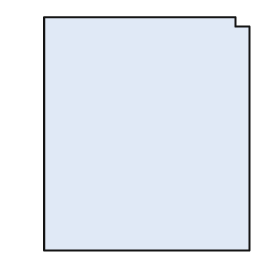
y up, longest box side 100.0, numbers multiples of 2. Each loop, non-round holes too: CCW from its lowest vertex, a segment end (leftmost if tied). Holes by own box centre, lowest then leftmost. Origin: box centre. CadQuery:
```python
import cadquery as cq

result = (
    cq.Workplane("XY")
    .moveTo(-44.0, -50.0)
    .lineTo(44.0, -50.0)
    .lineTo(44.0, 46.0)
    .lineTo(38.0, 46.0)
    .lineTo(38.0, 50.0)
    .lineTo(-44.0, 50.0)
    .close()
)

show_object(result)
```